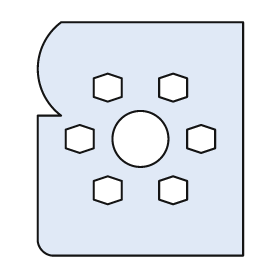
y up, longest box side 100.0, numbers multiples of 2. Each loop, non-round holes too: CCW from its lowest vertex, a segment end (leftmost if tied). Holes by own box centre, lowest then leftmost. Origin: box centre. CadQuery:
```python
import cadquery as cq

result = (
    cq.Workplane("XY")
    .moveTo(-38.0, -50.0)
    .lineTo(44.0, -50.0)
    .lineTo(44.0, 50.0)
    .lineTo(-34.0, 50.0)
    .threePointArc((-44.0, 30.0), (-34.0, 10.0))
    .lineTo(-44.0, 10.0)
    .lineTo(-44.0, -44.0)
    .threePointArc((-42.0, -48.0), (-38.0, -50.0))
    .close()
    .moveTo(-14.0, -28.0)
    .lineTo(-8.0, -26.0)
    .lineTo(-8.0, -18.0)
    .lineTo(-14.0, -16.0)
    .lineTo(-20.0, -18.0)
    .lineTo(-20.0, -26.0)
    .close()
    .moveTo(14.0, -28.0)
    .lineTo(20.0, -26.0)
    .lineTo(20.0, -18.0)
    .lineTo(14.0, -16.0)
    .lineTo(8.0, -18.0)
    .lineTo(8.0, -26.0)
    .close()
    .moveTo(-26.0, -6.0)
    .lineTo(-20.0, -4.0)
    .lineTo(-20.0, 4.0)
    .lineTo(-26.0, 6.0)
    .lineTo(-32.0, 4.0)
    .lineTo(-32.0, -4.0)
    .close()
    .moveTo(0.0, 0.0)
    .circle(12.0)
    .moveTo(26.0, -6.0)
    .lineTo(32.0, -4.0)
    .lineTo(32.0, 4.0)
    .lineTo(26.0, 6.0)
    .lineTo(20.0, 4.0)
    .lineTo(20.0, -4.0)
    .close()
    .moveTo(-14.0, 16.0)
    .lineTo(-8.0, 18.0)
    .lineTo(-8.0, 26.0)
    .lineTo(-14.0, 28.0)
    .lineTo(-20.0, 26.0)
    .lineTo(-20.0, 18.0)
    .close()
    .moveTo(14.0, 16.0)
    .lineTo(20.0, 18.0)
    .lineTo(20.0, 26.0)
    .lineTo(14.0, 28.0)
    .lineTo(8.0, 26.0)
    .lineTo(8.0, 18.0)
    .close()
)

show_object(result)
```